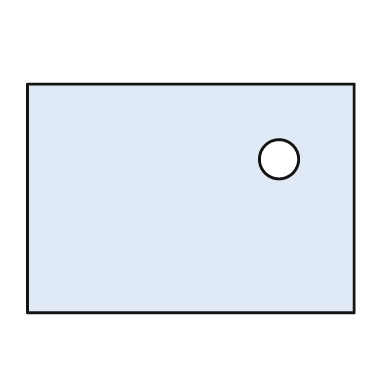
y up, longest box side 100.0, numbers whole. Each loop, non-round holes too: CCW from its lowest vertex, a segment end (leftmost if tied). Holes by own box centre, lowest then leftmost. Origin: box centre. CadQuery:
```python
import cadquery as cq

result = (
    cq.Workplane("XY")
    .moveTo(-50.0, -35.0)
    .lineTo(50.0, -35.0)
    .lineTo(50.0, 35.0)
    .lineTo(-50.0, 35.0)
    .close()
    .moveTo(27.0, 12.0)
    .circle(6.0)
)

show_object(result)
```